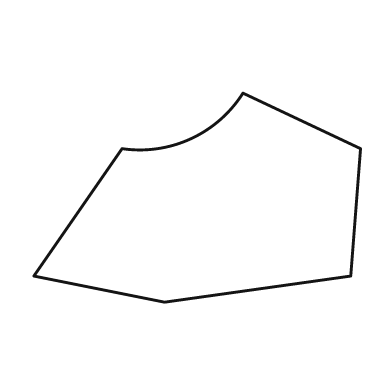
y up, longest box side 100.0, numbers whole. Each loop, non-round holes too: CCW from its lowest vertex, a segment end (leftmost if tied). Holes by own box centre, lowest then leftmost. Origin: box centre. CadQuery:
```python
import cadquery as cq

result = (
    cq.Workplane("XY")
    .moveTo(-10.0, -32.0)
    .lineTo(47.0, -24.0)
    .lineTo(50.0, 15.0)
    .lineTo(14.0, 32.0)
    .threePointArc((-2.0, 18.0), (-23.0, 15.0))
    .lineTo(-50.0, -24.0)
    .close()
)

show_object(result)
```